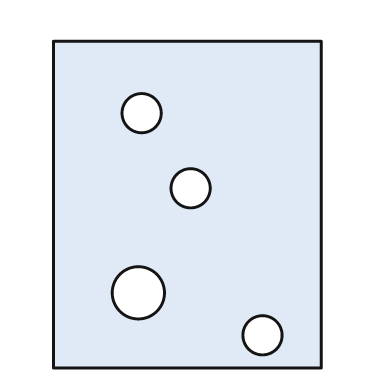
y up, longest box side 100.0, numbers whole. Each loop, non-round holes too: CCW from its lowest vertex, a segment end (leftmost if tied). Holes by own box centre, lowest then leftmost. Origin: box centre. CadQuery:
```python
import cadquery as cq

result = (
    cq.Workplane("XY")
    .moveTo(-41.0, -50.0)
    .lineTo(41.0, -50.0)
    .lineTo(41.0, 50.0)
    .lineTo(-41.0, 50.0)
    .close()
    .moveTo(23.0, -40.0)
    .circle(6.0)
    .moveTo(-15.0, -27.0)
    .circle(8.0)
    .moveTo(1.0, 5.0)
    .circle(6.0)
    .moveTo(-14.0, 28.0)
    .circle(6.0)
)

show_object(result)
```